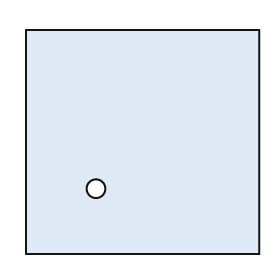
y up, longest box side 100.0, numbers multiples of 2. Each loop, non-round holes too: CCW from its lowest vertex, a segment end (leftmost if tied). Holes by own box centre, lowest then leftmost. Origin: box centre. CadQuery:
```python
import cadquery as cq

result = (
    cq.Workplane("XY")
    .moveTo(-50.0, -48.0)
    .lineTo(50.0, -48.0)
    .lineTo(50.0, 48.0)
    .lineTo(-50.0, 48.0)
    .close()
    .moveTo(-20.0, -20.0)
    .circle(4.0)
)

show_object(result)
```